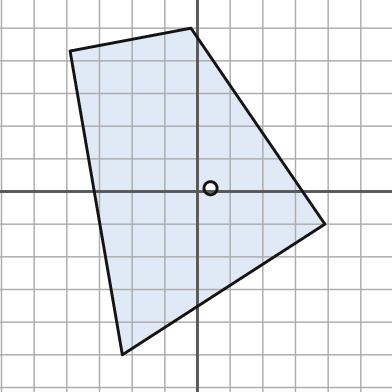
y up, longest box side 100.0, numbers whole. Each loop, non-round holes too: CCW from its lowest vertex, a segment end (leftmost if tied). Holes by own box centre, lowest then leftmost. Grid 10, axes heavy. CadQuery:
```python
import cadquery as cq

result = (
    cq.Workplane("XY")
    .moveTo(-23.0, -50.0)
    .lineTo(39.0, -10.0)
    .lineTo(-2.0, 50.0)
    .lineTo(-39.0, 43.0)
    .close()
    .moveTo(4.0, 1.0)
    .circle(2.0)
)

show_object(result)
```